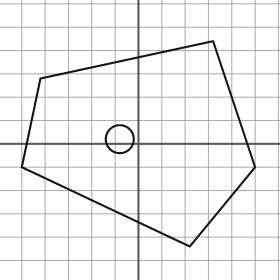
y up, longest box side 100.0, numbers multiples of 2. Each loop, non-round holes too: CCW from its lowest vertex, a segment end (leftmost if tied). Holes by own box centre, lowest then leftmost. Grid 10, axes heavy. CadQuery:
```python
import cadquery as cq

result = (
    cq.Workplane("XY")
    .moveTo(22.0, -44.0)
    .lineTo(50.0, -10.0)
    .lineTo(32.0, 44.0)
    .lineTo(-42.0, 28.0)
    .lineTo(-50.0, -10.0)
    .close()
    .moveTo(-8.0, 2.0)
    .circle(6.0)
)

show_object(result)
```